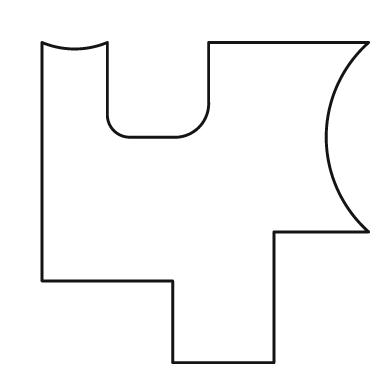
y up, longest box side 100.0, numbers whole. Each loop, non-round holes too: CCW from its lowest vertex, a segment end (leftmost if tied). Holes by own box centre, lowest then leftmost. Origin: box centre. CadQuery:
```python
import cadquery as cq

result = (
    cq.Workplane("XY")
    .moveTo(-10.0, -49.0)
    .lineTo(21.0, -49.0)
    .lineTo(21.0, -9.0)
    .lineTo(50.0, -9.0)
    .threePointArc((37.0, 20.0), (50.0, 49.0))
    .lineTo(1.0, 49.0)
    .lineTo(1.0, 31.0)
    .threePointArc((-2.0, 23.0), (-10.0, 20.0))
    .lineTo(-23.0, 20.0)
    .threePointArc((-28.0, 22.0), (-30.0, 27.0))
    .lineTo(-30.0, 49.0)
    .threePointArc((-40.0, 47.0), (-50.0, 49.0))
    .lineTo(-50.0, -24.0)
    .lineTo(-10.0, -24.0)
    .close()
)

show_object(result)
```